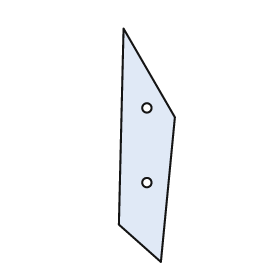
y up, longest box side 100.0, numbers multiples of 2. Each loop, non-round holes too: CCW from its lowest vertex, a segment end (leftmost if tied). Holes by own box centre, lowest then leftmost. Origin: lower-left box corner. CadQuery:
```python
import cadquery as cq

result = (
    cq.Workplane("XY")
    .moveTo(18.0, 0.0)
    .lineTo(24.0, 62.0)
    .lineTo(2.0, 100.0)
    .lineTo(0.0, 16.0)
    .close()
    .moveTo(12.0, 34.0)
    .circle(2.0)
    .moveTo(12.0, 66.0)
    .circle(2.0)
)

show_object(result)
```